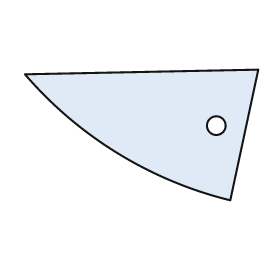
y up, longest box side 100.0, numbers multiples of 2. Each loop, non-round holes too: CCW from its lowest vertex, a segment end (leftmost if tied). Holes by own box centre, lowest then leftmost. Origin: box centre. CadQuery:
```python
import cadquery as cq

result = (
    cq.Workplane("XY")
    .moveTo(38.0, -28.0)
    .lineTo(50.0, 28.0)
    .lineTo(-50.0, 26.0)
    .threePointArc((-10.0, -8.0), (38.0, -28.0))
    .close()
    .moveTo(32.0, 4.0)
    .circle(4.0)
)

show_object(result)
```